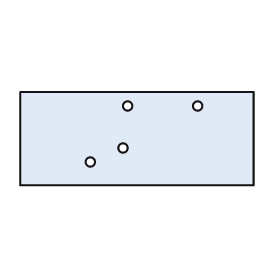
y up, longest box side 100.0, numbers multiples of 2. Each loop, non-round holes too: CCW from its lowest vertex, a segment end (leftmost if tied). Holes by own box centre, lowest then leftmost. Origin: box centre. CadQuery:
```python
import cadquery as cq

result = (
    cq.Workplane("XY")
    .moveTo(-50.0, -20.0)
    .lineTo(50.0, -20.0)
    .lineTo(50.0, 20.0)
    .lineTo(-50.0, 20.0)
    .close()
    .moveTo(-20.0, -10.0)
    .circle(2.0)
    .moveTo(-6.0, -4.0)
    .circle(2.0)
    .moveTo(-4.0, 14.0)
    .circle(2.0)
    .moveTo(26.0, 14.0)
    .circle(2.0)
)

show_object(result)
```